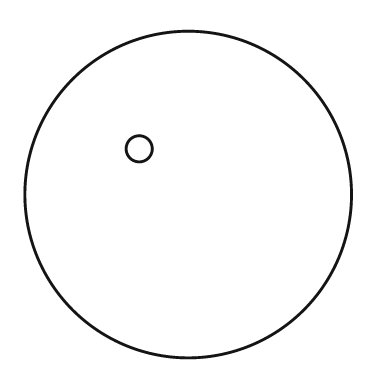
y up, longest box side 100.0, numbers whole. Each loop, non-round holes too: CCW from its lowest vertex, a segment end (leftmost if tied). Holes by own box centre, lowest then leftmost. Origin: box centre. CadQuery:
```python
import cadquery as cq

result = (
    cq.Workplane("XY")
    .moveTo(0.0, 0.0)
    .circle(50.0)
    .moveTo(-15.0, 14.0)
    .circle(4.0)
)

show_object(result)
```